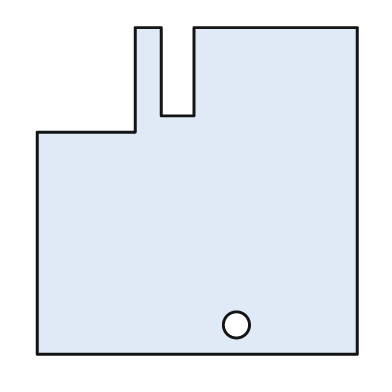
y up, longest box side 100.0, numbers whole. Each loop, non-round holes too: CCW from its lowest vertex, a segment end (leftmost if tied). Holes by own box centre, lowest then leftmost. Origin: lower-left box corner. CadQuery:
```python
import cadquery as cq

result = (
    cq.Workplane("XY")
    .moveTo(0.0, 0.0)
    .lineTo(98.0, 0.0)
    .lineTo(98.0, 100.0)
    .lineTo(48.0, 100.0)
    .lineTo(48.0, 73.0)
    .lineTo(38.0, 73.0)
    .lineTo(38.0, 100.0)
    .lineTo(30.0, 100.0)
    .lineTo(30.0, 68.0)
    .lineTo(0.0, 68.0)
    .close()
    .moveTo(61.0, 9.0)
    .circle(4.0)
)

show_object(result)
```